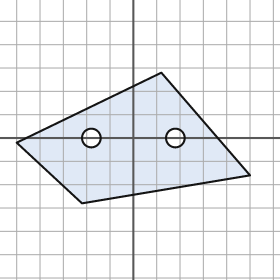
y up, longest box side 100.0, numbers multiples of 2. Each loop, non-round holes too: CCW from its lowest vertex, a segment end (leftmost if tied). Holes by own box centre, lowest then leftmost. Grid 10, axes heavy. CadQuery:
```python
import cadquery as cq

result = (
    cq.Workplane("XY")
    .moveTo(-22.0, -28.0)
    .lineTo(50.0, -16.0)
    .lineTo(12.0, 28.0)
    .lineTo(-50.0, -2.0)
    .close()
    .moveTo(-18.0, 0.0)
    .circle(4.0)
    .moveTo(18.0, 0.0)
    .circle(4.0)
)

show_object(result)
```